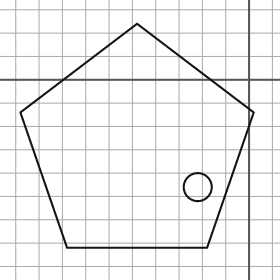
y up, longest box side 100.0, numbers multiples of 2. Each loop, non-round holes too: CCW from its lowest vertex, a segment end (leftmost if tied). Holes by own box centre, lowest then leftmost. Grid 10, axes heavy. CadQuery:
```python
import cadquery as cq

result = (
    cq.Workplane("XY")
    .moveTo(-78.0, -72.0)
    .lineTo(-18.0, -72.0)
    .lineTo(2.0, -14.0)
    .lineTo(-48.0, 24.0)
    .lineTo(-98.0, -14.0)
    .close()
    .moveTo(-22.0, -46.0)
    .circle(6.0)
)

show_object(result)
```